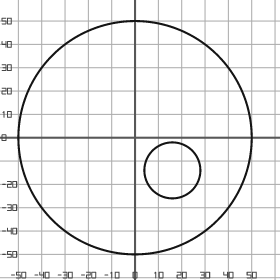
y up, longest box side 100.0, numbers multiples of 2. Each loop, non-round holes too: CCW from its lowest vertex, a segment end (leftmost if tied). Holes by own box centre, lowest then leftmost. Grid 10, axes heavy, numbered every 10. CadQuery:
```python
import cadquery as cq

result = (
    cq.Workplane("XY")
    .moveTo(0.0, 0.0)
    .circle(50.0)
    .moveTo(16.0, -14.0)
    .circle(12.0)
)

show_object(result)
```